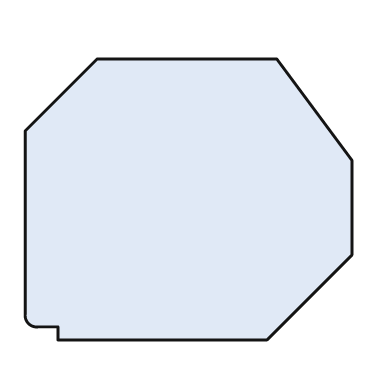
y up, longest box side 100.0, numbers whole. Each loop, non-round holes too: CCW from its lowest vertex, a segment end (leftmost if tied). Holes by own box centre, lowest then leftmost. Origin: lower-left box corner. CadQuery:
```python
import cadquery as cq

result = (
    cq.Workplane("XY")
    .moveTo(10.0, 0.0)
    .lineTo(74.0, 0.0)
    .lineTo(100.0, 26.0)
    .lineTo(100.0, 55.0)
    .lineTo(77.0, 86.0)
    .lineTo(22.0, 86.0)
    .lineTo(0.0, 64.0)
    .lineTo(0.0, 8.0)
    .threePointArc((1.0, 5.0), (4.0, 4.0))
    .lineTo(10.0, 4.0)
    .close()
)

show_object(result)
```